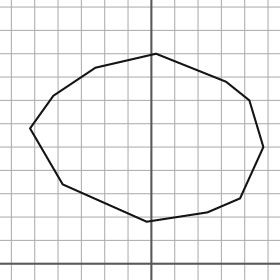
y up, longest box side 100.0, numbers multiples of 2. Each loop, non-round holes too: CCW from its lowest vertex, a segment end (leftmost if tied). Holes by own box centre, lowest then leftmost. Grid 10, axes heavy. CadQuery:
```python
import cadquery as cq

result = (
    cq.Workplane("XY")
    .moveTo(-2.0, 18.0)
    .lineTo(24.0, 22.0)
    .lineTo(38.0, 28.0)
    .lineTo(48.0, 50.0)
    .lineTo(42.0, 70.0)
    .lineTo(32.0, 78.0)
    .lineTo(2.0, 90.0)
    .lineTo(-24.0, 84.0)
    .lineTo(-42.0, 72.0)
    .lineTo(-52.0, 58.0)
    .lineTo(-38.0, 34.0)
    .close()
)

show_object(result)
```